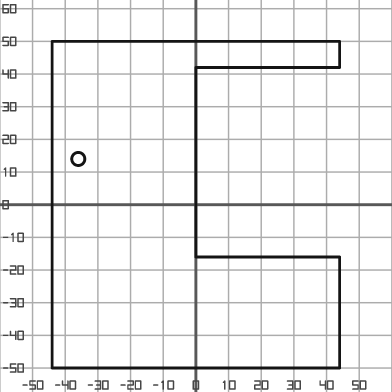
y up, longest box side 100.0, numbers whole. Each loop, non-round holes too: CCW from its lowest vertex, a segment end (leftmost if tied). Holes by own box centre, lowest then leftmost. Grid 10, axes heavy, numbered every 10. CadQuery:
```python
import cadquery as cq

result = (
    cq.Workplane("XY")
    .moveTo(-44.0, -50.0)
    .lineTo(44.0, -50.0)
    .lineTo(44.0, -16.0)
    .lineTo(0.0, -16.0)
    .lineTo(0.0, 42.0)
    .lineTo(44.0, 42.0)
    .lineTo(44.0, 50.0)
    .lineTo(-44.0, 50.0)
    .close()
    .moveTo(-36.0, 14.0)
    .circle(2.0)
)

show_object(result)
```